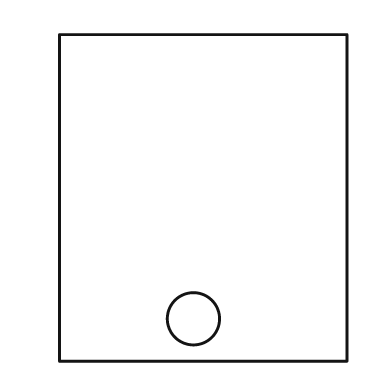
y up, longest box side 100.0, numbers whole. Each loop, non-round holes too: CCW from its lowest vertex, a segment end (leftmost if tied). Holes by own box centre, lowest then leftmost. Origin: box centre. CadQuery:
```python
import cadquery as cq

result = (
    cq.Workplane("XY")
    .moveTo(-44.0, -50.0)
    .lineTo(44.0, -50.0)
    .lineTo(44.0, 50.0)
    .lineTo(-44.0, 50.0)
    .close()
    .moveTo(-3.0, -37.0)
    .circle(8.0)
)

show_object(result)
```